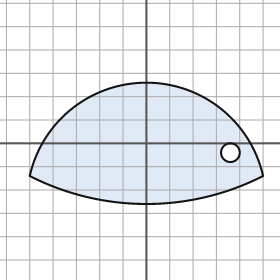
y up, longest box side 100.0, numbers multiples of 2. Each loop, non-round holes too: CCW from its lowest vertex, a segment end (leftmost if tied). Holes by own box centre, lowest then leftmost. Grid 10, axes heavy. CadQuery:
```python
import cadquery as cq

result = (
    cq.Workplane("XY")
    .moveTo(-50.0, -14.0)
    .threePointArc((0.0, -26.0), (50.0, -14.0))
    .threePointArc((0.0, 26.0), (-50.0, -14.0))
    .close()
    .moveTo(36.0, -4.0)
    .circle(4.0)
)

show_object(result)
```